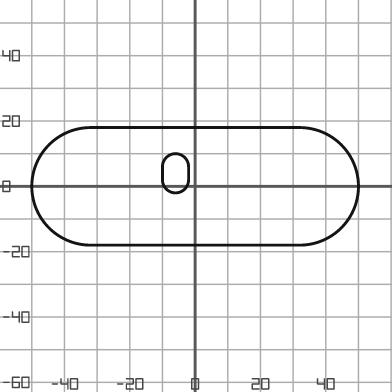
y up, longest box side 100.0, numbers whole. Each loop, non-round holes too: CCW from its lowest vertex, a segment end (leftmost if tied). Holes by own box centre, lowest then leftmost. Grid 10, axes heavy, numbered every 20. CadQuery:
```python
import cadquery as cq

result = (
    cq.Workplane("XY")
    .moveTo(-32.0, -18.0)
    .lineTo(32.0, -18.0)
    .threePointArc((50.0, 0.0), (32.0, 18.0))
    .lineTo(-32.0, 18.0)
    .threePointArc((-50.0, 0.0), (-32.0, -18.0))
    .close()
    .moveTo(-10.0, 2.0)
    .threePointArc((-6.0, -2.0), (-2.0, 2.0))
    .lineTo(-2.0, 6.0)
    .threePointArc((-6.0, 10.0), (-10.0, 6.0))
    .close()
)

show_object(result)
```